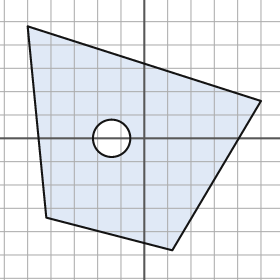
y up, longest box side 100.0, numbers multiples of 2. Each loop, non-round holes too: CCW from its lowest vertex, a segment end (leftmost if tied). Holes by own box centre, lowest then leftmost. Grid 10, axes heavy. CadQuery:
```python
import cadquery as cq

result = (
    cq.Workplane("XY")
    .moveTo(12.0, -48.0)
    .lineTo(50.0, 16.0)
    .lineTo(-50.0, 48.0)
    .lineTo(-42.0, -34.0)
    .close()
    .moveTo(-14.0, 0.0)
    .circle(8.0)
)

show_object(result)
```